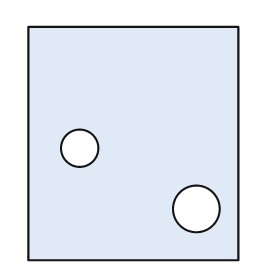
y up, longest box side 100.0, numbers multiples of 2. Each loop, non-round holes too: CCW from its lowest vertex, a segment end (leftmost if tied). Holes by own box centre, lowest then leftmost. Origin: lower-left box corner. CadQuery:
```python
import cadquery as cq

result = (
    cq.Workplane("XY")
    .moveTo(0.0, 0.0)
    .lineTo(90.0, 0.0)
    .lineTo(90.0, 100.0)
    .lineTo(0.0, 100.0)
    .close()
    .moveTo(72.0, 22.0)
    .circle(10.0)
    .moveTo(22.0, 48.0)
    .circle(8.0)
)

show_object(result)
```